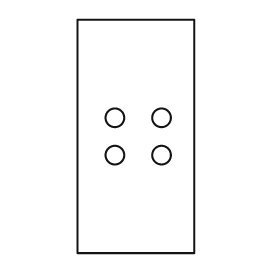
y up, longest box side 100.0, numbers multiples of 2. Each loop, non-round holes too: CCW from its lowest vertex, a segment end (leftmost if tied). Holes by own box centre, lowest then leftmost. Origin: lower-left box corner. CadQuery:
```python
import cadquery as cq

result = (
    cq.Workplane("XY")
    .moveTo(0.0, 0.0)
    .lineTo(50.0, 0.0)
    .lineTo(50.0, 100.0)
    .lineTo(0.0, 100.0)
    .close()
    .moveTo(16.0, 42.0)
    .circle(4.0)
    .moveTo(36.0, 42.0)
    .circle(4.0)
    .moveTo(16.0, 58.0)
    .circle(4.0)
    .moveTo(36.0, 58.0)
    .circle(4.0)
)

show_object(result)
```